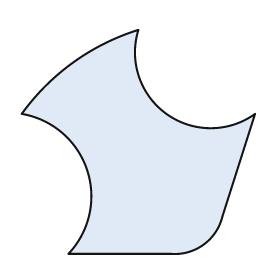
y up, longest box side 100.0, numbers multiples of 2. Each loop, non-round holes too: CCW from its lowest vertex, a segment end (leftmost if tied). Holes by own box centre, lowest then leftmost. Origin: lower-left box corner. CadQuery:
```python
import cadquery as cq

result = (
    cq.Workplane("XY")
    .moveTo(20.0, 0.0)
    .lineTo(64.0, 0.0)
    .threePointArc((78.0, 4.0), (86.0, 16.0))
    .lineTo(100.0, 60.0)
    .threePointArc((62.0, 60.0), (50.0, 96.0))
    .threePointArc((22.0, 82.0), (0.0, 60.0))
    .threePointArc((28.0, 36.0), (20.0, 0.0))
    .close()
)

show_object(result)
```